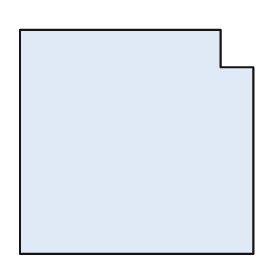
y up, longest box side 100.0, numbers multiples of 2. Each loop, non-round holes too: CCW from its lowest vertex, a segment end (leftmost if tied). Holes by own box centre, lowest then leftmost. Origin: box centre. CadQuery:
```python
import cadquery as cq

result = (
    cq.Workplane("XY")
    .moveTo(-50.0, -48.0)
    .lineTo(50.0, -48.0)
    .lineTo(50.0, 32.0)
    .lineTo(36.0, 32.0)
    .lineTo(36.0, 48.0)
    .lineTo(-50.0, 48.0)
    .close()
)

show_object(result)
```